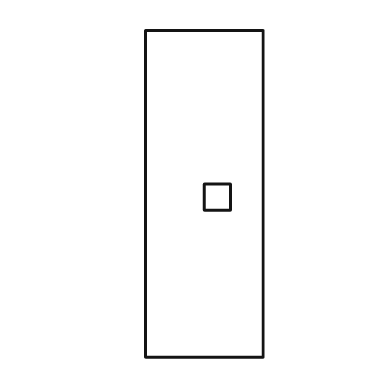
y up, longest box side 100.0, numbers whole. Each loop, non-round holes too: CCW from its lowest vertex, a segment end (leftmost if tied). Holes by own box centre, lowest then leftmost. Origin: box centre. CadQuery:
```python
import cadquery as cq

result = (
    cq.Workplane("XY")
    .moveTo(-18.0, -50.0)
    .lineTo(18.0, -50.0)
    .lineTo(18.0, 50.0)
    .lineTo(-18.0, 50.0)
    .close()
    .moveTo(0.0, -5.0)
    .lineTo(8.0, -5.0)
    .lineTo(8.0, 3.0)
    .lineTo(0.0, 3.0)
    .close()
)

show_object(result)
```